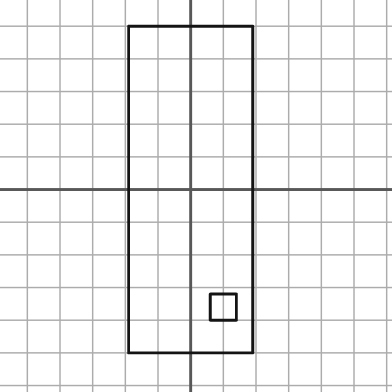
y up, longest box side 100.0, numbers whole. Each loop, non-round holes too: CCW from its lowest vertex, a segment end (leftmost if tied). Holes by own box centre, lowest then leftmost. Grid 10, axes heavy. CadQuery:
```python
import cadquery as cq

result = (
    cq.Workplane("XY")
    .moveTo(-19.0, -50.0)
    .lineTo(19.0, -50.0)
    .lineTo(19.0, 50.0)
    .lineTo(-19.0, 50.0)
    .close()
    .moveTo(6.0, -40.0)
    .lineTo(14.0, -40.0)
    .lineTo(14.0, -32.0)
    .lineTo(6.0, -32.0)
    .close()
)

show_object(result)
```